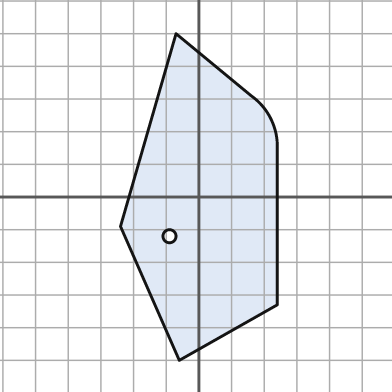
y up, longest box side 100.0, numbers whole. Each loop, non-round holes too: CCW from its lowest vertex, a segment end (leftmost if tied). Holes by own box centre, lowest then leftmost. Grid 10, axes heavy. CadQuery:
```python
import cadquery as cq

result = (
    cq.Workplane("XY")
    .moveTo(-6.0, -50.0)
    .lineTo(24.0, -33.0)
    .lineTo(24.0, 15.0)
    .threePointArc((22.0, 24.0), (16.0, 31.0))
    .lineTo(-7.0, 50.0)
    .lineTo(-24.0, -9.0)
    .close()
    .moveTo(-9.0, -12.0)
    .circle(2.0)
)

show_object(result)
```